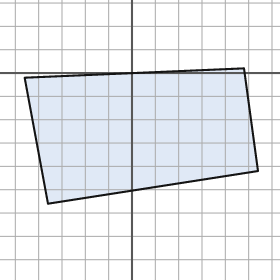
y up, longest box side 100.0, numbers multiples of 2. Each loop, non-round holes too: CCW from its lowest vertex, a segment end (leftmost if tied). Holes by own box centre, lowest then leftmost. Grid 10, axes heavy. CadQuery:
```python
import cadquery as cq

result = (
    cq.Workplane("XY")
    .moveTo(-36.0, -56.0)
    .lineTo(54.0, -42.0)
    .lineTo(48.0, 2.0)
    .lineTo(-46.0, -2.0)
    .close()
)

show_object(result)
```